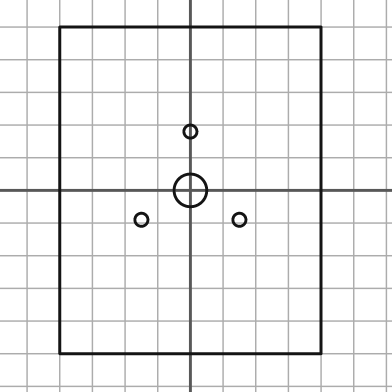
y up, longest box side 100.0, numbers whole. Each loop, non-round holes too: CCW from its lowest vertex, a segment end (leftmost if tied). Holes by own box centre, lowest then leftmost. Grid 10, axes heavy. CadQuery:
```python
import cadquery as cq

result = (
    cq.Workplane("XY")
    .moveTo(-40.0, -50.0)
    .lineTo(40.0, -50.0)
    .lineTo(40.0, 50.0)
    .lineTo(-40.0, 50.0)
    .close()
    .moveTo(-15.0, -9.0)
    .circle(2.0)
    .moveTo(15.0, -9.0)
    .circle(2.0)
    .moveTo(0.0, 0.0)
    .circle(5.0)
    .moveTo(0.0, 18.0)
    .circle(2.0)
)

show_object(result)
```